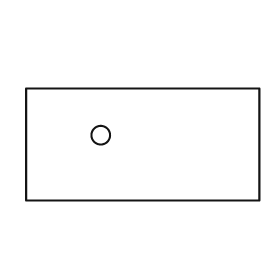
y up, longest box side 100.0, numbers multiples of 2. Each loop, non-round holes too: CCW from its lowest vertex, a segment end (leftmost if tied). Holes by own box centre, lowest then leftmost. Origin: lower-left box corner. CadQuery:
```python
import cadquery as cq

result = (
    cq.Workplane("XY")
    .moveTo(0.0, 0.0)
    .lineTo(100.0, 0.0)
    .lineTo(100.0, 48.0)
    .lineTo(0.0, 48.0)
    .close()
    .moveTo(32.0, 28.0)
    .circle(4.0)
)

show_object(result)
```